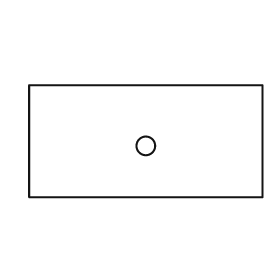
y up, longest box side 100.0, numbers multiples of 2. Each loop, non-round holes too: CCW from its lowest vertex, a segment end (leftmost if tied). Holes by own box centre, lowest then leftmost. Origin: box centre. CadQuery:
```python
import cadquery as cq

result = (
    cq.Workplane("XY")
    .moveTo(-50.0, -24.0)
    .lineTo(50.0, -24.0)
    .lineTo(50.0, 24.0)
    .lineTo(-50.0, 24.0)
    .close()
    .moveTo(0.0, -2.0)
    .circle(4.0)
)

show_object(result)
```